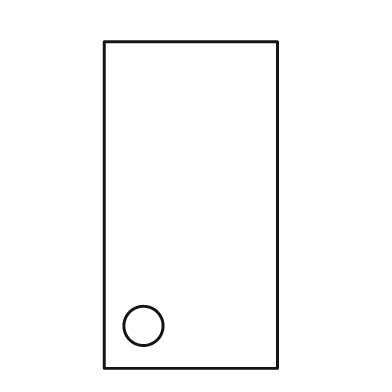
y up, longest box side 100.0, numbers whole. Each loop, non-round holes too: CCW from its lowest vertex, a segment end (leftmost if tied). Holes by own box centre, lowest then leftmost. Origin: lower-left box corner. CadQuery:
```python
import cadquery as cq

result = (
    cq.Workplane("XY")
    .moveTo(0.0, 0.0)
    .lineTo(53.0, 0.0)
    .lineTo(53.0, 100.0)
    .lineTo(0.0, 100.0)
    .close()
    .moveTo(12.0, 13.0)
    .circle(6.0)
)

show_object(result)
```